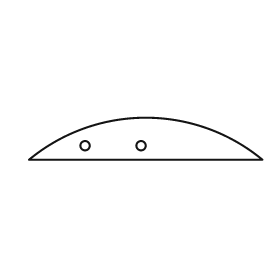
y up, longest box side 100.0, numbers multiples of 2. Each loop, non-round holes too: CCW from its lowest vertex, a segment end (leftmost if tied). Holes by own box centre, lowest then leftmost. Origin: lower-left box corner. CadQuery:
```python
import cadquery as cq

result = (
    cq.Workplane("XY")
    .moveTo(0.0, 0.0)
    .lineTo(100.0, 0.0)
    .threePointArc((50.0, 18.0), (0.0, 0.0))
    .close()
    .moveTo(24.0, 6.0)
    .circle(2.0)
    .moveTo(48.0, 6.0)
    .circle(2.0)
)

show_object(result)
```